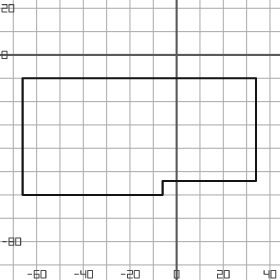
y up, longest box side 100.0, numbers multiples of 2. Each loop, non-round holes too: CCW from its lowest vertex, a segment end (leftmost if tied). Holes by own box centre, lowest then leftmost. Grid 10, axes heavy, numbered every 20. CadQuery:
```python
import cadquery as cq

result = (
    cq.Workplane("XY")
    .moveTo(-66.0, -60.0)
    .lineTo(-6.0, -60.0)
    .lineTo(-6.0, -54.0)
    .lineTo(34.0, -54.0)
    .lineTo(34.0, -10.0)
    .lineTo(-66.0, -10.0)
    .close()
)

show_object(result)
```